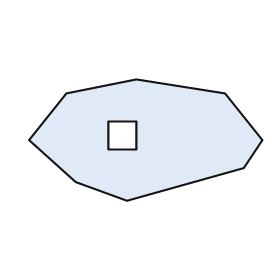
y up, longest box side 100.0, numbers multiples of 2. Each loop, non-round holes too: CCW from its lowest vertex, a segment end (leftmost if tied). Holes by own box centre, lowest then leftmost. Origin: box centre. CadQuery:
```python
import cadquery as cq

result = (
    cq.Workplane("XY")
    .moveTo(-8.0, -26.0)
    .lineTo(42.0, -12.0)
    .lineTo(50.0, 0.0)
    .lineTo(34.0, 20.0)
    .lineTo(-4.0, 26.0)
    .lineTo(-34.0, 20.0)
    .lineTo(-50.0, 0.0)
    .lineTo(-30.0, -18.0)
    .close()
    .moveTo(-16.0, -4.0)
    .lineTo(-4.0, -4.0)
    .lineTo(-4.0, 8.0)
    .lineTo(-16.0, 8.0)
    .close()
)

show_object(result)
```